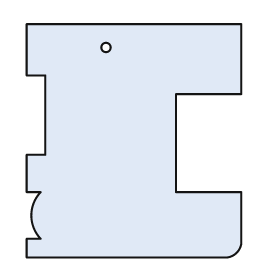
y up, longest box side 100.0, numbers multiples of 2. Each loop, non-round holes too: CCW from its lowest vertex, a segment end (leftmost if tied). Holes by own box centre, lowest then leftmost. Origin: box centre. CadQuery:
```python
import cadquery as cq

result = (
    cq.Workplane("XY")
    .moveTo(-46.0, -50.0)
    .lineTo(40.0, -50.0)
    .threePointArc((44.0, -48.0), (46.0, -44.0))
    .lineTo(46.0, -22.0)
    .lineTo(18.0, -22.0)
    .lineTo(18.0, 20.0)
    .lineTo(46.0, 20.0)
    .lineTo(46.0, 50.0)
    .lineTo(-46.0, 50.0)
    .lineTo(-46.0, 28.0)
    .lineTo(-38.0, 28.0)
    .lineTo(-38.0, -6.0)
    .lineTo(-46.0, -6.0)
    .lineTo(-46.0, -22.0)
    .lineTo(-40.0, -22.0)
    .threePointArc((-44.0, -32.0), (-40.0, -42.0))
    .lineTo(-46.0, -42.0)
    .close()
    .moveTo(-12.0, 40.0)
    .circle(2.0)
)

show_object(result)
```